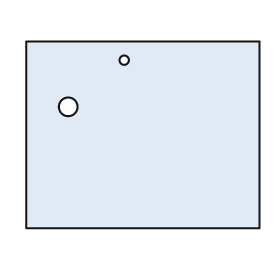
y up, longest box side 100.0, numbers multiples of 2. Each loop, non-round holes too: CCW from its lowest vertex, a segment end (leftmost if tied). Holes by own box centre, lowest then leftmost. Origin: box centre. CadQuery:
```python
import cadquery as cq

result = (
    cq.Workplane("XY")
    .moveTo(-50.0, -40.0)
    .lineTo(50.0, -40.0)
    .lineTo(50.0, 40.0)
    .lineTo(-50.0, 40.0)
    .close()
    .moveTo(-32.0, 12.0)
    .circle(4.0)
    .moveTo(-8.0, 32.0)
    .circle(2.0)
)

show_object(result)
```